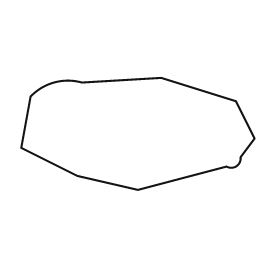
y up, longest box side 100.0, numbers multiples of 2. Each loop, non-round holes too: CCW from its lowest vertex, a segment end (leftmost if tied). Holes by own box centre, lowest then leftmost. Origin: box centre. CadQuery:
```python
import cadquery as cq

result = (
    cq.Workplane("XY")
    .moveTo(0.0, -24.0)
    .lineTo(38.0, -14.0)
    .threePointArc((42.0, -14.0), (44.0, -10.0))
    .lineTo(50.0, -2.0)
    .lineTo(42.0, 14.0)
    .lineTo(10.0, 24.0)
    .lineTo(-24.0, 22.0)
    .threePointArc((-36.0, 22.0), (-46.0, 16.0))
    .lineTo(-50.0, -6.0)
    .lineTo(-26.0, -18.0)
    .close()
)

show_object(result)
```